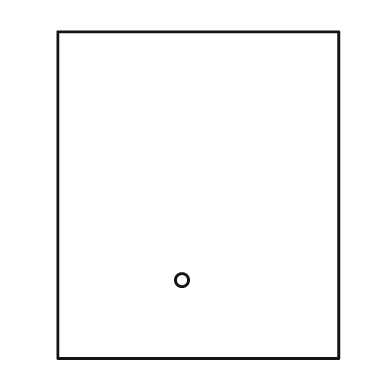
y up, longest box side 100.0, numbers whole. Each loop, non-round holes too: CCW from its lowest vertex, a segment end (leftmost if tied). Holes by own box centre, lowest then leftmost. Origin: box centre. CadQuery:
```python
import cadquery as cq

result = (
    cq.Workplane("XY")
    .moveTo(-43.0, -50.0)
    .lineTo(43.0, -50.0)
    .lineTo(43.0, 50.0)
    .lineTo(-43.0, 50.0)
    .close()
    .moveTo(-5.0, -26.0)
    .circle(2.0)
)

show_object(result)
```